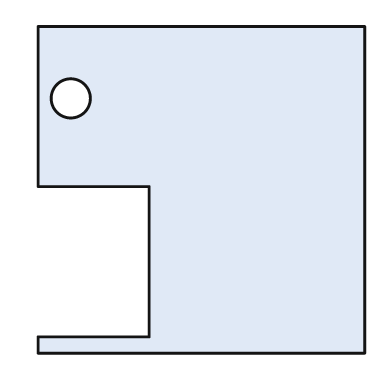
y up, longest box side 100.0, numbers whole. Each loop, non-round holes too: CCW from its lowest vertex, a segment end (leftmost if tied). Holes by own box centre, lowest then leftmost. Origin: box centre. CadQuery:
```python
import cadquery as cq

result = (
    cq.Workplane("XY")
    .moveTo(-50.0, -50.0)
    .lineTo(50.0, -50.0)
    .lineTo(50.0, 50.0)
    .lineTo(-50.0, 50.0)
    .lineTo(-50.0, 1.0)
    .lineTo(-16.0, 1.0)
    .lineTo(-16.0, -45.0)
    .lineTo(-50.0, -45.0)
    .close()
    .moveTo(-40.0, 28.0)
    .circle(6.0)
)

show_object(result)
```